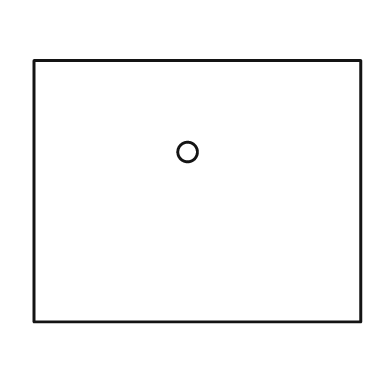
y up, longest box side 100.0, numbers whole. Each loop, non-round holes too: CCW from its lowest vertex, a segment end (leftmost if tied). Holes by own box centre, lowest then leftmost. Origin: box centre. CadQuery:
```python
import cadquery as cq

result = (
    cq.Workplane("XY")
    .moveTo(-50.0, -40.0)
    .lineTo(50.0, -40.0)
    .lineTo(50.0, 40.0)
    .lineTo(-50.0, 40.0)
    .close()
    .moveTo(-3.0, 12.0)
    .circle(3.0)
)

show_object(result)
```